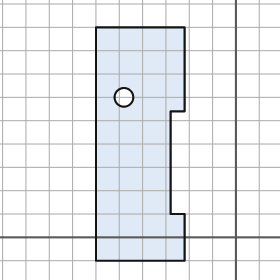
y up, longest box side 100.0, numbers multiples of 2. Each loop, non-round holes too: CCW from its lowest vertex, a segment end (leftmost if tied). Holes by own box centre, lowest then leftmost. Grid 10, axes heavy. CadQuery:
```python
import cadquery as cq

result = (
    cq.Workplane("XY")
    .moveTo(-60.0, -10.0)
    .lineTo(-22.0, -10.0)
    .lineTo(-22.0, 10.0)
    .lineTo(-28.0, 10.0)
    .lineTo(-28.0, 54.0)
    .lineTo(-22.0, 54.0)
    .lineTo(-22.0, 90.0)
    .lineTo(-60.0, 90.0)
    .close()
    .moveTo(-48.0, 60.0)
    .circle(4.0)
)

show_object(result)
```